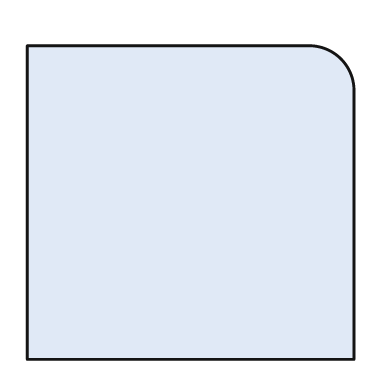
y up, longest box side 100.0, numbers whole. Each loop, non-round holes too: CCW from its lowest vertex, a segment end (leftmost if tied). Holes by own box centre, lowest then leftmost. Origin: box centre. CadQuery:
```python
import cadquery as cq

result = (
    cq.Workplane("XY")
    .moveTo(-50.0, -48.0)
    .lineTo(50.0, -48.0)
    .lineTo(50.0, 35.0)
    .threePointArc((46.0, 44.0), (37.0, 48.0))
    .lineTo(-50.0, 48.0)
    .close()
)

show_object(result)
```